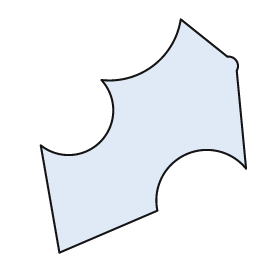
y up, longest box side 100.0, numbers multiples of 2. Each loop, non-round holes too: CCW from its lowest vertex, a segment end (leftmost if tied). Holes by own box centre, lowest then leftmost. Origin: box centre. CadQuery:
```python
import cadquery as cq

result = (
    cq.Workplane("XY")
    .moveTo(-36.0, -50.0)
    .lineTo(6.0, -32.0)
    .threePointArc((18.0, -8.0), (44.0, -14.0))
    .lineTo(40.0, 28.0)
    .threePointArc((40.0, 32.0), (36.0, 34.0))
    .lineTo(16.0, 50.0)
    .threePointArc((4.0, 30.0), (-18.0, 24.0))
    .threePointArc((-18.0, -2.0), (-44.0, -4.0))
    .close()
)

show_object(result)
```